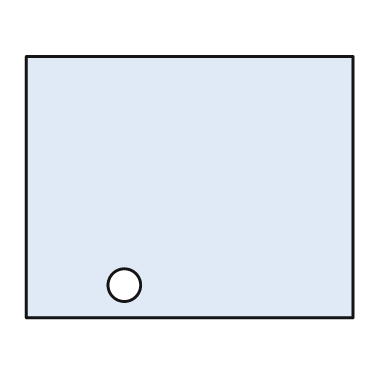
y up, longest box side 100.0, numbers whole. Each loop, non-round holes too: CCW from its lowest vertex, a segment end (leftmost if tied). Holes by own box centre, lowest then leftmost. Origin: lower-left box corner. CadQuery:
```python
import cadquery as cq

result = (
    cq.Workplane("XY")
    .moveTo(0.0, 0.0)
    .lineTo(100.0, 0.0)
    .lineTo(100.0, 80.0)
    .lineTo(0.0, 80.0)
    .close()
    .moveTo(30.0, 10.0)
    .circle(5.0)
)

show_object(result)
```